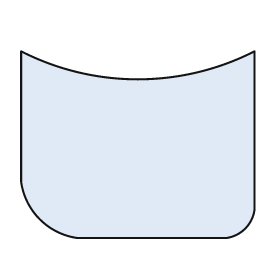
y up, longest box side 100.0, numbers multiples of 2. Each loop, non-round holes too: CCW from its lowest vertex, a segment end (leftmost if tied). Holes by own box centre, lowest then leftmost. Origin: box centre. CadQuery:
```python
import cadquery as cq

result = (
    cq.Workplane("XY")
    .moveTo(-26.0, -40.0)
    .lineTo(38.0, -40.0)
    .threePointArc((46.0, -36.0), (50.0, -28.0))
    .lineTo(50.0, 40.0)
    .threePointArc((0.0, 28.0), (-50.0, 40.0))
    .lineTo(-50.0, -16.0)
    .threePointArc((-42.0, -32.0), (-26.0, -40.0))
    .close()
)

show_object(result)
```